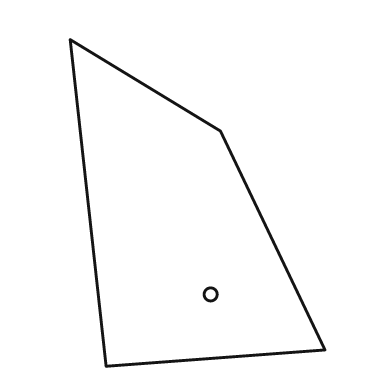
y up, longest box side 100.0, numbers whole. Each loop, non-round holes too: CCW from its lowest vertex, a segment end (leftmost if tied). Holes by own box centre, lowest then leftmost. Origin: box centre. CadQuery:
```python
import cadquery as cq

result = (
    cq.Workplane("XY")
    .moveTo(-28.0, -50.0)
    .lineTo(39.0, -45.0)
    .lineTo(7.0, 22.0)
    .lineTo(-39.0, 50.0)
    .close()
    .moveTo(4.0, -28.0)
    .circle(2.0)
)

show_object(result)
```